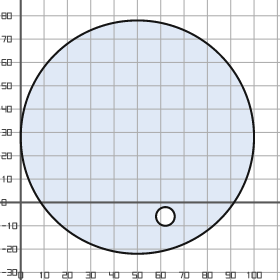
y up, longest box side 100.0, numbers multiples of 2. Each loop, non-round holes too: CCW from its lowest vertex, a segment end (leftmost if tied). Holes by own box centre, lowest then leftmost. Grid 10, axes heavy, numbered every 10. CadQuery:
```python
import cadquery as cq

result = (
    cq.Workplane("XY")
    .moveTo(50.0, 28.0)
    .circle(50.0)
    .moveTo(62.0, -6.0)
    .circle(4.0)
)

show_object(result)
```